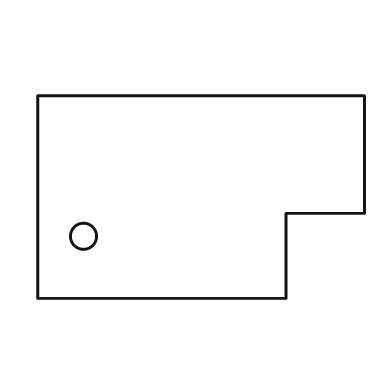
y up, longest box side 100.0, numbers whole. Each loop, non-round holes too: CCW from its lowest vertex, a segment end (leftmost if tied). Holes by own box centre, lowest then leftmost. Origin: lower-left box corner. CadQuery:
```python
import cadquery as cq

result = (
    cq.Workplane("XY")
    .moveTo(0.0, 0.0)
    .lineTo(76.0, 0.0)
    .lineTo(76.0, 26.0)
    .lineTo(100.0, 26.0)
    .lineTo(100.0, 62.0)
    .lineTo(0.0, 62.0)
    .close()
    .moveTo(14.0, 19.0)
    .circle(4.0)
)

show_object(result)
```